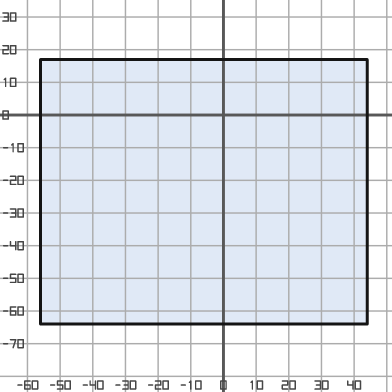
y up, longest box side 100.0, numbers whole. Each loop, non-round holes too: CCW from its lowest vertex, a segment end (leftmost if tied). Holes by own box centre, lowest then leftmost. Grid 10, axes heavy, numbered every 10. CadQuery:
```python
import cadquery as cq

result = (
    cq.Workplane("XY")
    .moveTo(-56.0, -64.0)
    .lineTo(44.0, -64.0)
    .lineTo(44.0, 17.0)
    .lineTo(-56.0, 17.0)
    .close()
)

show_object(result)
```